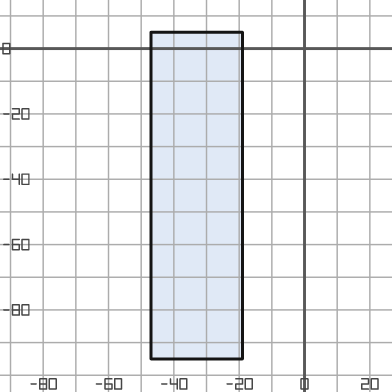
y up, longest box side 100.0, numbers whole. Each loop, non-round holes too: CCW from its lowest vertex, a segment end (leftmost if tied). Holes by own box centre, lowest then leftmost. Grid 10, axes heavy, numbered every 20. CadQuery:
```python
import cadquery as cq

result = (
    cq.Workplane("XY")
    .moveTo(-47.0, -95.0)
    .lineTo(-19.0, -95.0)
    .lineTo(-19.0, 5.0)
    .lineTo(-47.0, 5.0)
    .close()
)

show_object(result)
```